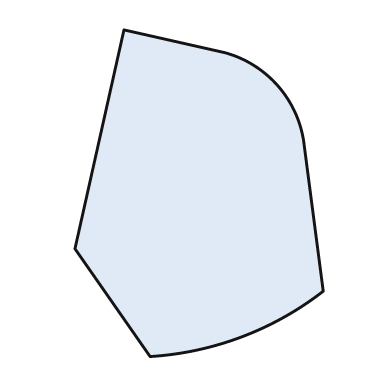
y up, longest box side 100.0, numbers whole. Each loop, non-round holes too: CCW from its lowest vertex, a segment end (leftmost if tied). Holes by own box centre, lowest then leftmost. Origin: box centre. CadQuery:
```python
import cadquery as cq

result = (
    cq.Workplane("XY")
    .moveTo(-15.0, -50.0)
    .threePointArc((13.0, -44.0), (38.0, -30.0))
    .lineTo(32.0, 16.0)
    .threePointArc((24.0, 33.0), (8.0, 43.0))
    .lineTo(-23.0, 50.0)
    .lineTo(-38.0, -17.0)
    .close()
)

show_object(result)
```